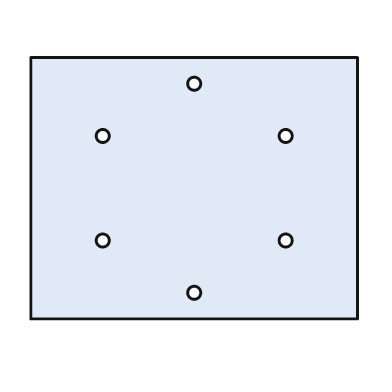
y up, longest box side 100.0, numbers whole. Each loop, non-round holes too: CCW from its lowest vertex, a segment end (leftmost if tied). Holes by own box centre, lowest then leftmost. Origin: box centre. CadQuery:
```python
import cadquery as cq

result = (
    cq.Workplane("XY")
    .moveTo(-50.0, -40.0)
    .lineTo(50.0, -40.0)
    .lineTo(50.0, 40.0)
    .lineTo(-50.0, 40.0)
    .close()
    .moveTo(0.0, -32.0)
    .circle(2.0)
    .moveTo(-28.0, -16.0)
    .circle(2.0)
    .moveTo(28.0, -16.0)
    .circle(2.0)
    .moveTo(-28.0, 16.0)
    .circle(2.0)
    .moveTo(28.0, 16.0)
    .circle(2.0)
    .moveTo(0.0, 32.0)
    .circle(2.0)
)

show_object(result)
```